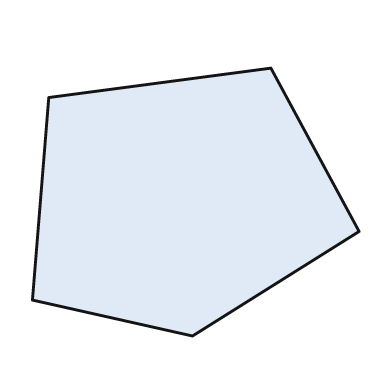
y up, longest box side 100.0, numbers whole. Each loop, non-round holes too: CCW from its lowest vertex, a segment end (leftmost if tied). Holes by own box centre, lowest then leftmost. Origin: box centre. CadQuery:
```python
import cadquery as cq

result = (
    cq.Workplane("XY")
    .moveTo(-1.0, -41.0)
    .lineTo(50.0, -9.0)
    .lineTo(23.0, 41.0)
    .lineTo(-45.0, 32.0)
    .lineTo(-50.0, -30.0)
    .close()
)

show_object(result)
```